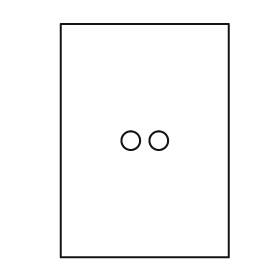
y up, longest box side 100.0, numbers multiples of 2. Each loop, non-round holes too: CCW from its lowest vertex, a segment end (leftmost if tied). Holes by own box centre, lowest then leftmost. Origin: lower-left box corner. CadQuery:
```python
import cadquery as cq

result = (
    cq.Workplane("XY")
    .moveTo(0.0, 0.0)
    .lineTo(72.0, 0.0)
    .lineTo(72.0, 100.0)
    .lineTo(0.0, 100.0)
    .close()
    .moveTo(30.0, 50.0)
    .circle(4.0)
    .moveTo(42.0, 50.0)
    .circle(4.0)
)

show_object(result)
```